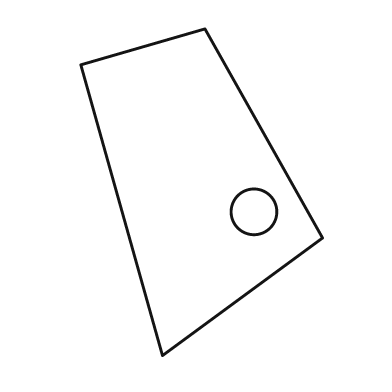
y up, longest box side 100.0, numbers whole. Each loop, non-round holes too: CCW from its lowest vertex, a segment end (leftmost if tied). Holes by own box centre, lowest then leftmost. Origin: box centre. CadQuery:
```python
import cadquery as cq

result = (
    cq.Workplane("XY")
    .moveTo(-12.0, -50.0)
    .lineTo(37.0, -14.0)
    .lineTo(1.0, 50.0)
    .lineTo(-37.0, 39.0)
    .close()
    .moveTo(16.0, -6.0)
    .circle(7.0)
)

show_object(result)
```